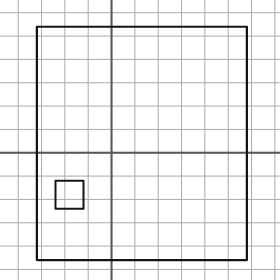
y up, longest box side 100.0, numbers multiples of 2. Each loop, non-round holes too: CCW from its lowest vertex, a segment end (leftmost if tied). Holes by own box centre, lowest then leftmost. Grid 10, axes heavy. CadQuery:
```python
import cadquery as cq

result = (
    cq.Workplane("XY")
    .moveTo(-32.0, -46.0)
    .lineTo(58.0, -46.0)
    .lineTo(58.0, 54.0)
    .lineTo(-32.0, 54.0)
    .close()
    .moveTo(-24.0, -24.0)
    .lineTo(-12.0, -24.0)
    .lineTo(-12.0, -12.0)
    .lineTo(-24.0, -12.0)
    .close()
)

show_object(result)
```